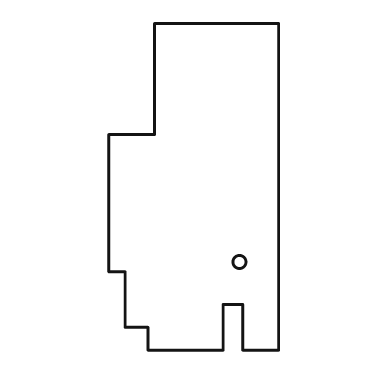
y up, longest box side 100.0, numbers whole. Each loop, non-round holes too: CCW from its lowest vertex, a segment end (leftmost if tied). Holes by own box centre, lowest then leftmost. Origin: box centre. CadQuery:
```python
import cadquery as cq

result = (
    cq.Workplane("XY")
    .moveTo(-14.0, -50.0)
    .lineTo(9.0, -50.0)
    .lineTo(9.0, -36.0)
    .lineTo(15.0, -36.0)
    .lineTo(15.0, -50.0)
    .lineTo(26.0, -50.0)
    .lineTo(26.0, 50.0)
    .lineTo(-12.0, 50.0)
    .lineTo(-12.0, 16.0)
    .lineTo(-26.0, 16.0)
    .lineTo(-26.0, -26.0)
    .lineTo(-21.0, -26.0)
    .lineTo(-21.0, -43.0)
    .lineTo(-14.0, -43.0)
    .close()
    .moveTo(14.0, -23.0)
    .circle(2.0)
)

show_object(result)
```